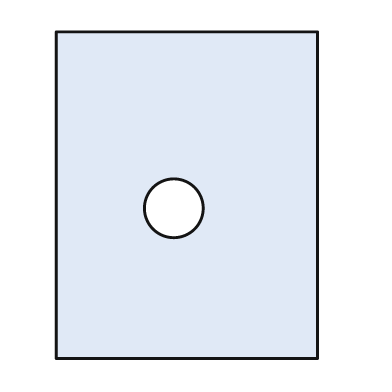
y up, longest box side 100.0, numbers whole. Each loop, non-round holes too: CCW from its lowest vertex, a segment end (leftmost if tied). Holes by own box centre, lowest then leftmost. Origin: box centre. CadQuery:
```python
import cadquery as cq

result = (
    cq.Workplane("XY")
    .moveTo(-40.0, -50.0)
    .lineTo(40.0, -50.0)
    .lineTo(40.0, 50.0)
    .lineTo(-40.0, 50.0)
    .close()
    .moveTo(-4.0, -4.0)
    .circle(9.0)
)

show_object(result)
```